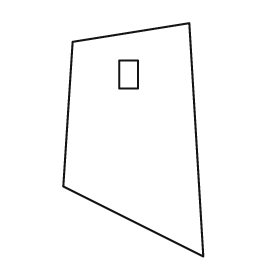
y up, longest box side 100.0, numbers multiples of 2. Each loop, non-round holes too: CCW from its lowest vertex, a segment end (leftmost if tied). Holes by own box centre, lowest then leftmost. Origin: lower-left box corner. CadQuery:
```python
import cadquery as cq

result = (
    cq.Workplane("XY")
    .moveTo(60.0, 0.0)
    .lineTo(54.0, 100.0)
    .lineTo(4.0, 92.0)
    .lineTo(0.0, 30.0)
    .close()
    .moveTo(24.0, 72.0)
    .lineTo(32.0, 72.0)
    .lineTo(32.0, 84.0)
    .lineTo(24.0, 84.0)
    .close()
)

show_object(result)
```